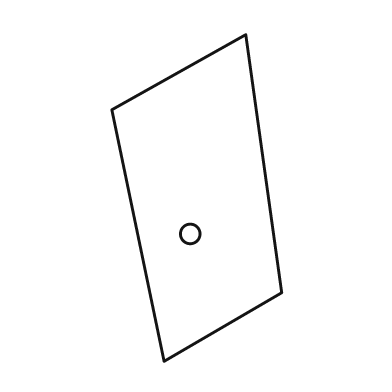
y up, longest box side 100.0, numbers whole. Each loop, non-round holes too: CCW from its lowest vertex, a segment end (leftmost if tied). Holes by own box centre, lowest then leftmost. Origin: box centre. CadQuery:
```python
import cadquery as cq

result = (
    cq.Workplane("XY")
    .moveTo(-10.0, -50.0)
    .lineTo(26.0, -29.0)
    .lineTo(15.0, 50.0)
    .lineTo(-26.0, 27.0)
    .close()
    .moveTo(-2.0, -11.0)
    .circle(3.0)
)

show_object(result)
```